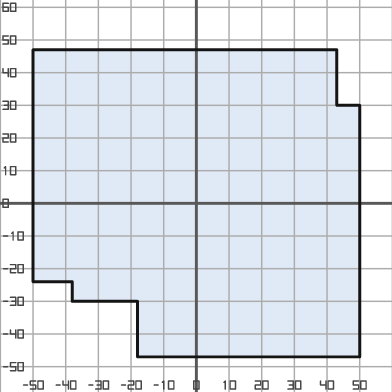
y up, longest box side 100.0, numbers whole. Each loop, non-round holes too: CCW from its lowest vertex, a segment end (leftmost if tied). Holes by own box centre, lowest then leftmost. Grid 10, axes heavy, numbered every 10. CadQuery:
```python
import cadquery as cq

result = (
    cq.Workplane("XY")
    .moveTo(-18.0, -47.0)
    .lineTo(50.0, -47.0)
    .lineTo(50.0, 30.0)
    .lineTo(43.0, 30.0)
    .lineTo(43.0, 47.0)
    .lineTo(-50.0, 47.0)
    .lineTo(-50.0, -24.0)
    .lineTo(-38.0, -24.0)
    .lineTo(-38.0, -30.0)
    .lineTo(-18.0, -30.0)
    .close()
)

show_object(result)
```